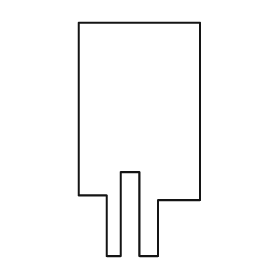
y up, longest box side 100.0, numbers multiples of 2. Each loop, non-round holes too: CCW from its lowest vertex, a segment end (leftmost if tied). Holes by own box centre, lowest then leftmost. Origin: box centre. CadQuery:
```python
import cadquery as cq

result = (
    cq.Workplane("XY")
    .moveTo(-14.0, -50.0)
    .lineTo(-8.0, -50.0)
    .lineTo(-8.0, -14.0)
    .lineTo(0.0, -14.0)
    .lineTo(0.0, -50.0)
    .lineTo(8.0, -50.0)
    .lineTo(8.0, -26.0)
    .lineTo(26.0, -26.0)
    .lineTo(26.0, 50.0)
    .lineTo(-26.0, 50.0)
    .lineTo(-26.0, -24.0)
    .lineTo(-14.0, -24.0)
    .close()
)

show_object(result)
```